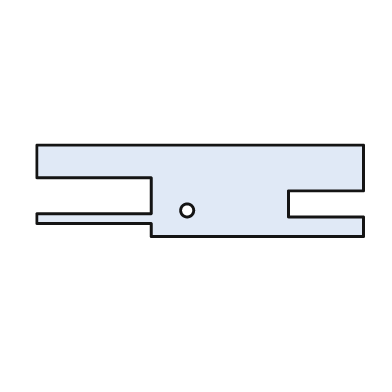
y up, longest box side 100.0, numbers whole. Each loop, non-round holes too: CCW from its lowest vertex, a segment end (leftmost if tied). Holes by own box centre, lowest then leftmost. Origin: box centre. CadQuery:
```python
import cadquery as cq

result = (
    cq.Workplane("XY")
    .moveTo(-15.0, -14.0)
    .lineTo(50.0, -14.0)
    .lineTo(50.0, -8.0)
    .lineTo(27.0, -8.0)
    .lineTo(27.0, 0.0)
    .lineTo(50.0, 0.0)
    .lineTo(50.0, 14.0)
    .lineTo(-50.0, 14.0)
    .lineTo(-50.0, 4.0)
    .lineTo(-15.0, 4.0)
    .lineTo(-15.0, -7.0)
    .lineTo(-50.0, -7.0)
    .lineTo(-50.0, -10.0)
    .lineTo(-15.0, -10.0)
    .close()
    .moveTo(-4.0, -6.0)
    .circle(2.0)
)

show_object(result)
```